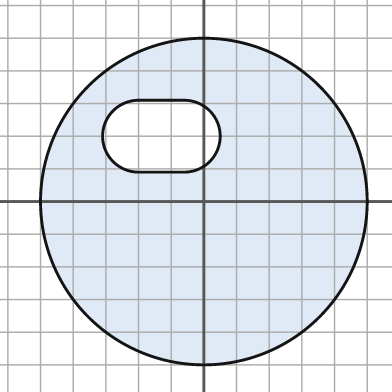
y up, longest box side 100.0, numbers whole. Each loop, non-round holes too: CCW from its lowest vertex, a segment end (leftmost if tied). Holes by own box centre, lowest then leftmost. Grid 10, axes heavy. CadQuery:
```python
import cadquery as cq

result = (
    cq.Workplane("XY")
    .moveTo(0.0, 0.0)
    .circle(50.0)
    .moveTo(-20.0, 9.0)
    .lineTo(-6.0, 9.0)
    .threePointArc((5.0, 20.0), (-6.0, 31.0))
    .lineTo(-20.0, 31.0)
    .threePointArc((-31.0, 20.0), (-20.0, 9.0))
    .close()
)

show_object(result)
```